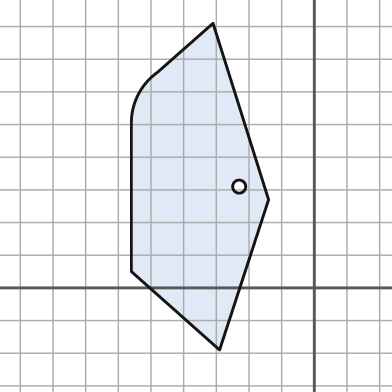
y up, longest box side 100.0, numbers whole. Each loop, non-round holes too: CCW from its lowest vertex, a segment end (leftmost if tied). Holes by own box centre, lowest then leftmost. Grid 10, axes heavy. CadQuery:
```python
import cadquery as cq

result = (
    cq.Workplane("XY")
    .moveTo(-29.0, -19.0)
    .lineTo(-14.0, 27.0)
    .lineTo(-31.0, 81.0)
    .lineTo(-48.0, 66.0)
    .threePointArc((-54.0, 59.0), (-56.0, 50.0))
    .lineTo(-56.0, 5.0)
    .close()
    .moveTo(-23.0, 31.0)
    .circle(2.0)
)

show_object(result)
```